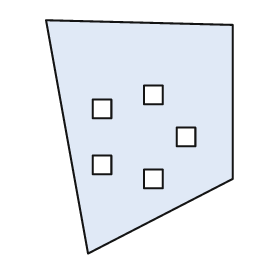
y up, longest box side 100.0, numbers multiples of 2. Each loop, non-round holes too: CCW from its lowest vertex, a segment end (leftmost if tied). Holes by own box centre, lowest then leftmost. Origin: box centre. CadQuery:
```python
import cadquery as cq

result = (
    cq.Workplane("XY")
    .moveTo(-22.0, -50.0)
    .lineTo(40.0, -18.0)
    .lineTo(40.0, 48.0)
    .lineTo(-40.0, 50.0)
    .close()
    .moveTo(2.0, -22.0)
    .lineTo(10.0, -22.0)
    .lineTo(10.0, -14.0)
    .lineTo(2.0, -14.0)
    .close()
    .moveTo(-20.0, -16.0)
    .lineTo(-12.0, -16.0)
    .lineTo(-12.0, -8.0)
    .lineTo(-20.0, -8.0)
    .close()
    .moveTo(16.0, -4.0)
    .lineTo(24.0, -4.0)
    .lineTo(24.0, 4.0)
    .lineTo(16.0, 4.0)
    .close()
    .moveTo(-20.0, 8.0)
    .lineTo(-12.0, 8.0)
    .lineTo(-12.0, 16.0)
    .lineTo(-20.0, 16.0)
    .close()
    .moveTo(2.0, 14.0)
    .lineTo(10.0, 14.0)
    .lineTo(10.0, 22.0)
    .lineTo(2.0, 22.0)
    .close()
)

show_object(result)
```